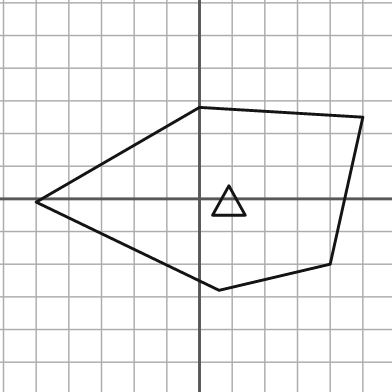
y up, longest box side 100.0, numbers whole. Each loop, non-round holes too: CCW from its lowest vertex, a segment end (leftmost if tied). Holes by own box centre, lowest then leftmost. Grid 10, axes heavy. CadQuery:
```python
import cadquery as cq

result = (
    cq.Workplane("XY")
    .moveTo(6.0, -28.0)
    .lineTo(40.0, -20.0)
    .lineTo(50.0, 25.0)
    .lineTo(0.0, 28.0)
    .lineTo(-50.0, -1.0)
    .close()
    .moveTo(4.0, -5.0)
    .lineTo(14.0, -5.0)
    .lineTo(9.0, 4.0)
    .close()
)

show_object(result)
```